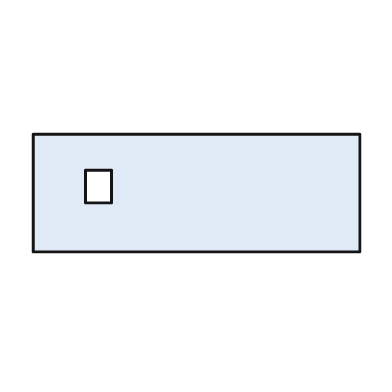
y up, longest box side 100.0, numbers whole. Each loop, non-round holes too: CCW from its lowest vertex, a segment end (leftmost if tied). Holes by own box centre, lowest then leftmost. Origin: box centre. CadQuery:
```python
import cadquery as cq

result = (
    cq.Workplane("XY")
    .moveTo(-50.0, -18.0)
    .lineTo(50.0, -18.0)
    .lineTo(50.0, 18.0)
    .lineTo(-50.0, 18.0)
    .close()
    .moveTo(-34.0, -3.0)
    .lineTo(-26.0, -3.0)
    .lineTo(-26.0, 7.0)
    .lineTo(-34.0, 7.0)
    .close()
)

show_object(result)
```